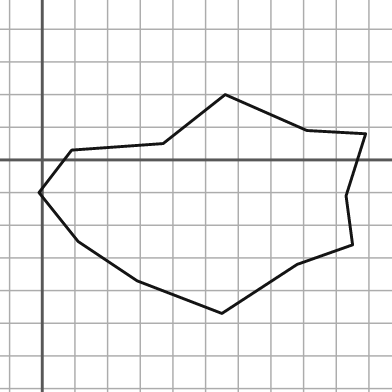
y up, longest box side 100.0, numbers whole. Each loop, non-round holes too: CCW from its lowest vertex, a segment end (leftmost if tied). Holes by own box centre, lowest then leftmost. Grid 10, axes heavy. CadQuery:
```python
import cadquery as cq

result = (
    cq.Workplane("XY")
    .moveTo(55.0, -47.0)
    .lineTo(78.0, -32.0)
    .lineTo(95.0, -26.0)
    .lineTo(93.0, -11.0)
    .lineTo(99.0, 8.0)
    .lineTo(81.0, 9.0)
    .lineTo(56.0, 20.0)
    .lineTo(37.0, 5.0)
    .lineTo(9.0, 3.0)
    .lineTo(-1.0, -10.0)
    .lineTo(11.0, -25.0)
    .lineTo(29.0, -37.0)
    .close()
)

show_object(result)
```